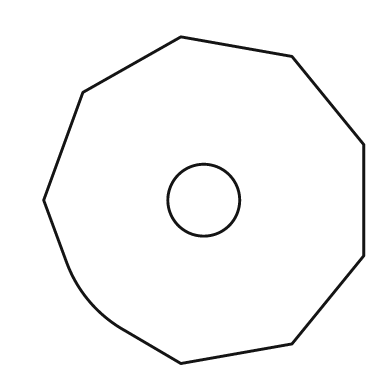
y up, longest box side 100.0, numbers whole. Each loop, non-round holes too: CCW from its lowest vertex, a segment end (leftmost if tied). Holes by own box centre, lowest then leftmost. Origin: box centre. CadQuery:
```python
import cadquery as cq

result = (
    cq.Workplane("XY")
    .moveTo(-7.0, -50.0)
    .lineTo(27.0, -44.0)
    .lineTo(49.0, -17.0)
    .lineTo(49.0, 17.0)
    .lineTo(27.0, 44.0)
    .lineTo(-7.0, 50.0)
    .lineTo(-37.0, 33.0)
    .lineTo(-49.0, 0.0)
    .lineTo(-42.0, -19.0)
    .threePointArc((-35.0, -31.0), (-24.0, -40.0))
    .close()
    .moveTo(0.0, 0.0)
    .circle(11.0)
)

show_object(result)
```